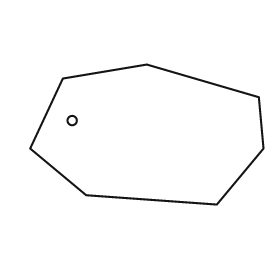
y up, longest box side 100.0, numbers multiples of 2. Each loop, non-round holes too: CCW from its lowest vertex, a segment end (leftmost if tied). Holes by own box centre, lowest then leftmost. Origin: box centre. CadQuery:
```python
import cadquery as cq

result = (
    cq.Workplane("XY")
    .moveTo(30.0, -30.0)
    .lineTo(50.0, -6.0)
    .lineTo(48.0, 16.0)
    .lineTo(0.0, 30.0)
    .lineTo(-36.0, 24.0)
    .lineTo(-50.0, -6.0)
    .lineTo(-26.0, -26.0)
    .close()
    .moveTo(-32.0, 6.0)
    .circle(2.0)
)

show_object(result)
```